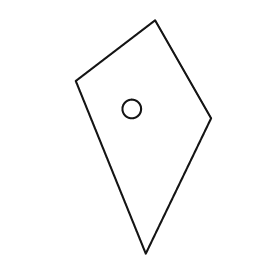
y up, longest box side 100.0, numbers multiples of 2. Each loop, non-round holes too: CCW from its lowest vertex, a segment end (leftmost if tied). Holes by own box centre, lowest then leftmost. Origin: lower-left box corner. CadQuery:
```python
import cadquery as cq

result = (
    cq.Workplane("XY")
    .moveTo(30.0, 0.0)
    .lineTo(58.0, 58.0)
    .lineTo(34.0, 100.0)
    .lineTo(0.0, 74.0)
    .close()
    .moveTo(24.0, 62.0)
    .circle(4.0)
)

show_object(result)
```